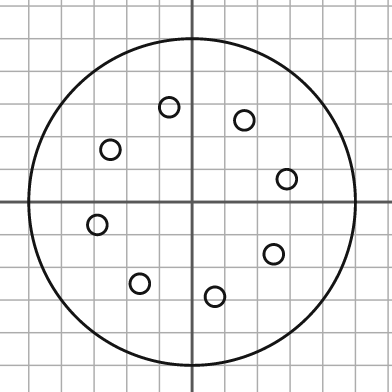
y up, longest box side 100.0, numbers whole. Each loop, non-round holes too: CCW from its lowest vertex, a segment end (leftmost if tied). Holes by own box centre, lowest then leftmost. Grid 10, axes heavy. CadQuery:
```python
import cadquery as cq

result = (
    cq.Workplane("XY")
    .moveTo(0.0, 0.0)
    .circle(50.0)
    .moveTo(7.0, -29.0)
    .circle(3.0)
    .moveTo(-16.0, -25.0)
    .circle(3.0)
    .moveTo(25.0, -16.0)
    .circle(3.0)
    .moveTo(-29.0, -7.0)
    .circle(3.0)
    .moveTo(29.0, 7.0)
    .circle(3.0)
    .moveTo(-25.0, 16.0)
    .circle(3.0)
    .moveTo(16.0, 25.0)
    .circle(3.0)
    .moveTo(-7.0, 29.0)
    .circle(3.0)
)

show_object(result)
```